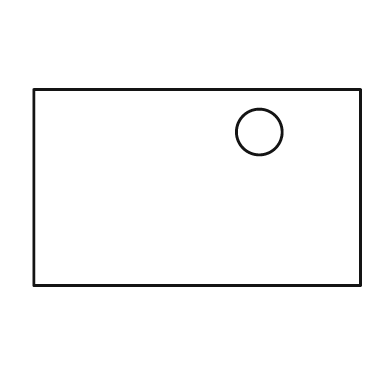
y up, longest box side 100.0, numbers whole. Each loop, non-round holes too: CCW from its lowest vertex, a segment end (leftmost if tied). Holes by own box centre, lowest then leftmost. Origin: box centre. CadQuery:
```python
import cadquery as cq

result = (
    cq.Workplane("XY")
    .moveTo(-50.0, -30.0)
    .lineTo(50.0, -30.0)
    .lineTo(50.0, 30.0)
    .lineTo(-50.0, 30.0)
    .close()
    .moveTo(19.0, 17.0)
    .circle(7.0)
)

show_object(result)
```